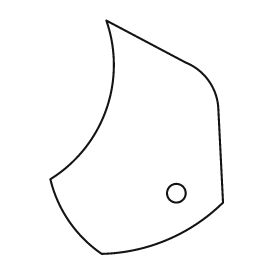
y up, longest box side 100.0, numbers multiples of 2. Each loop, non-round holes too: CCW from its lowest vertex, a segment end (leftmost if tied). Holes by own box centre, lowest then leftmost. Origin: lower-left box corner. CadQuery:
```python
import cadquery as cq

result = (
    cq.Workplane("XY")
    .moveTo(22.0, 0.0)
    .threePointArc((50.0, 6.0), (74.0, 22.0))
    .lineTo(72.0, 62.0)
    .threePointArc((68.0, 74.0), (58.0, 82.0))
    .lineTo(24.0, 100.0)
    .threePointArc((24.0, 62.0), (0.0, 32.0))
    .threePointArc((8.0, 14.0), (22.0, 0.0))
    .close()
    .moveTo(54.0, 26.0)
    .circle(4.0)
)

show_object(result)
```